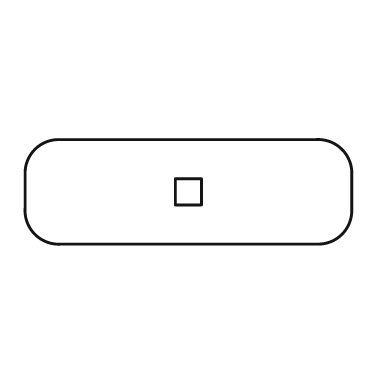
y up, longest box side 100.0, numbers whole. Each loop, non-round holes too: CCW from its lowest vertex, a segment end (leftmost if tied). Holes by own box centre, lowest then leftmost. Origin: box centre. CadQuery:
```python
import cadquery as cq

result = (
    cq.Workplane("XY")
    .moveTo(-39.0, -16.0)
    .lineTo(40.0, -16.0)
    .threePointArc((47.0, -13.0), (50.0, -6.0))
    .lineTo(50.0, 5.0)
    .threePointArc((47.0, 13.0), (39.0, 16.0))
    .lineTo(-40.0, 16.0)
    .threePointArc((-47.0, 13.0), (-50.0, 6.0))
    .lineTo(-50.0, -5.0)
    .threePointArc((-47.0, -13.0), (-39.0, -16.0))
    .close()
    .moveTo(-4.0, -4.0)
    .lineTo(4.0, -4.0)
    .lineTo(4.0, 4.0)
    .lineTo(-4.0, 4.0)
    .close()
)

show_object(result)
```